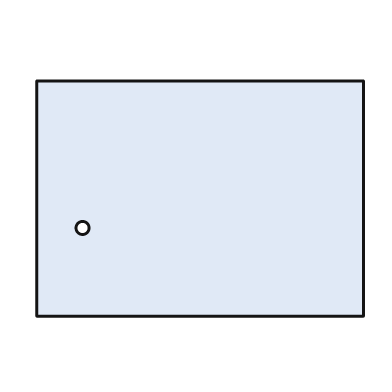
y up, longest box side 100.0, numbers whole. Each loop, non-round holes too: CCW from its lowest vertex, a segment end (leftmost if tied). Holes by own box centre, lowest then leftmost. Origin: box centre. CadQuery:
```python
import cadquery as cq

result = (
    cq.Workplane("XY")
    .moveTo(-50.0, -36.0)
    .lineTo(50.0, -36.0)
    .lineTo(50.0, 36.0)
    .lineTo(-50.0, 36.0)
    .close()
    .moveTo(-36.0, -9.0)
    .circle(2.0)
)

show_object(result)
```